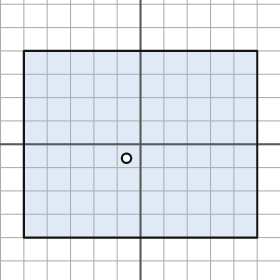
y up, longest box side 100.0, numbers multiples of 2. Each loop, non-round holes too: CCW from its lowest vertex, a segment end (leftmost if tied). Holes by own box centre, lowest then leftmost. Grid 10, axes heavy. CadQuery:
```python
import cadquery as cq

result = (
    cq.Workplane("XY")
    .moveTo(-50.0, -40.0)
    .lineTo(50.0, -40.0)
    .lineTo(50.0, 40.0)
    .lineTo(-50.0, 40.0)
    .close()
    .moveTo(-6.0, -6.0)
    .circle(2.0)
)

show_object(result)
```